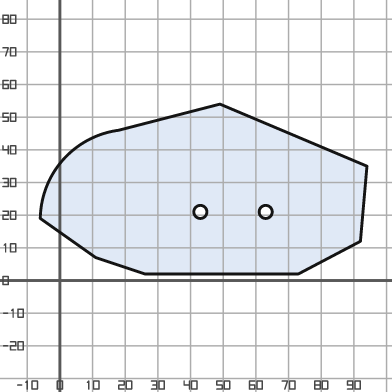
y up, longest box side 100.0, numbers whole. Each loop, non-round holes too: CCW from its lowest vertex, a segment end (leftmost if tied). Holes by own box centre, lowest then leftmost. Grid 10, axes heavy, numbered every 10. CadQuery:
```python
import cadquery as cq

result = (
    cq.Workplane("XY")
    .moveTo(26.0, 2.0)
    .lineTo(73.0, 2.0)
    .lineTo(92.0, 12.0)
    .lineTo(94.0, 35.0)
    .lineTo(49.0, 54.0)
    .lineTo(18.0, 46.0)
    .threePointArc((1.0, 37.0), (-6.0, 19.0))
    .lineTo(11.0, 7.0)
    .close()
    .moveTo(43.0, 21.0)
    .circle(2.0)
    .moveTo(63.0, 21.0)
    .circle(2.0)
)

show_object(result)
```